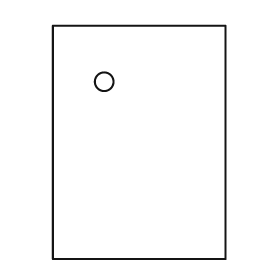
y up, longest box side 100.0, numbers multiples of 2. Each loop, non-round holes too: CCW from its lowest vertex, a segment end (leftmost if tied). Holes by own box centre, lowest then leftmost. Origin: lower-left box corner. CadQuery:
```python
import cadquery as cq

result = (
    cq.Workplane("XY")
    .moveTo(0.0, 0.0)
    .lineTo(74.0, 0.0)
    .lineTo(74.0, 100.0)
    .lineTo(0.0, 100.0)
    .close()
    .moveTo(22.0, 76.0)
    .circle(4.0)
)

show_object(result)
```